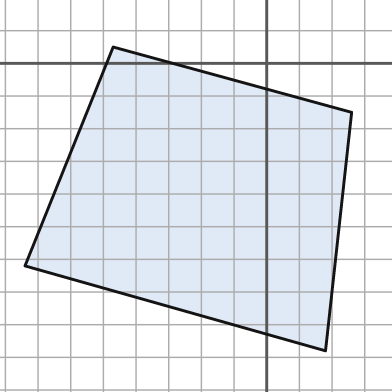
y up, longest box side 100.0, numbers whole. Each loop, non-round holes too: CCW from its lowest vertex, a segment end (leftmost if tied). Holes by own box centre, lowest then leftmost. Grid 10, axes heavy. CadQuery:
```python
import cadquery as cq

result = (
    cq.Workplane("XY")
    .moveTo(18.0, -88.0)
    .lineTo(26.0, -15.0)
    .lineTo(-47.0, 5.0)
    .lineTo(-74.0, -62.0)
    .close()
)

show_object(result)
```